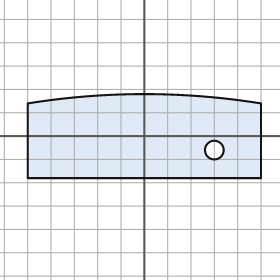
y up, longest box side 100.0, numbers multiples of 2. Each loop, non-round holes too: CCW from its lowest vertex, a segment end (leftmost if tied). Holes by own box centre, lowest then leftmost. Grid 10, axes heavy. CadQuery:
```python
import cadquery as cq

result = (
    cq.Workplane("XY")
    .moveTo(-50.0, -18.0)
    .lineTo(50.0, -18.0)
    .lineTo(50.0, 14.0)
    .threePointArc((0.0, 18.0), (-50.0, 14.0))
    .close()
    .moveTo(30.0, -6.0)
    .circle(4.0)
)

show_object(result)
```